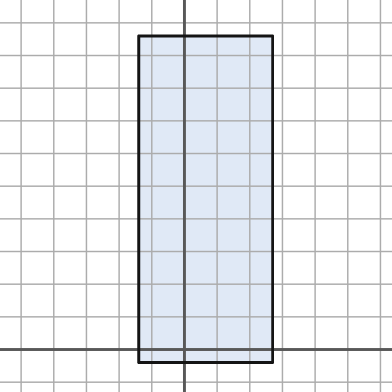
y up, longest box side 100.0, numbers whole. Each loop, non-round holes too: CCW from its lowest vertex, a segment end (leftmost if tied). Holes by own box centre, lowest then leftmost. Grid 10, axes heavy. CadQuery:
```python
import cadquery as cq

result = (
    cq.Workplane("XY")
    .moveTo(-14.0, -4.0)
    .lineTo(27.0, -4.0)
    .lineTo(27.0, 96.0)
    .lineTo(-14.0, 96.0)
    .close()
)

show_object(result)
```